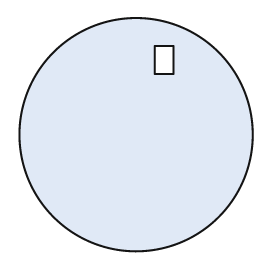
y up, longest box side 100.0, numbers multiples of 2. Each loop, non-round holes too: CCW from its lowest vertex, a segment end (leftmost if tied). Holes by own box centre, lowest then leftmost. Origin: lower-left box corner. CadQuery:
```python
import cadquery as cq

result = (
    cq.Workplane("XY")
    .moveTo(50.0, 50.0)
    .circle(50.0)
    .moveTo(58.0, 76.0)
    .lineTo(66.0, 76.0)
    .lineTo(66.0, 88.0)
    .lineTo(58.0, 88.0)
    .close()
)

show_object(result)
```